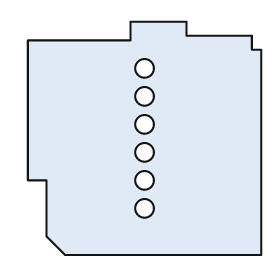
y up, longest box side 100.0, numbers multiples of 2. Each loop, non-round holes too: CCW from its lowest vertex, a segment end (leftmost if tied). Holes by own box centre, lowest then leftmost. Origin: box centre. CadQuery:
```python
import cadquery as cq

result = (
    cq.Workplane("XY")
    .moveTo(-34.0, -50.0)
    .lineTo(50.0, -50.0)
    .lineTo(50.0, 38.0)
    .lineTo(46.0, 38.0)
    .lineTo(46.0, 44.0)
    .lineTo(18.0, 44.0)
    .lineTo(18.0, 50.0)
    .lineTo(-6.0, 50.0)
    .lineTo(-6.0, 42.0)
    .lineTo(-50.0, 42.0)
    .lineTo(-50.0, -18.0)
    .lineTo(-42.0, -18.0)
    .lineTo(-42.0, -42.0)
    .close()
    .moveTo(0.0, -30.0)
    .circle(4.0)
    .moveTo(0.0, -18.0)
    .circle(4.0)
    .moveTo(0.0, -6.0)
    .circle(4.0)
    .moveTo(0.0, 6.0)
    .circle(4.0)
    .moveTo(0.0, 18.0)
    .circle(4.0)
    .moveTo(0.0, 30.0)
    .circle(4.0)
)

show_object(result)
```